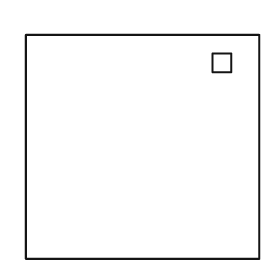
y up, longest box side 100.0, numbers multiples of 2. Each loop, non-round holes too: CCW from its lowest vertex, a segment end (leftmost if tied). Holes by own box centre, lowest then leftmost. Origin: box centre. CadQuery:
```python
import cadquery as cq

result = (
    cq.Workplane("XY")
    .moveTo(-50.0, -48.0)
    .lineTo(50.0, -48.0)
    .lineTo(50.0, 48.0)
    .lineTo(-50.0, 48.0)
    .close()
    .moveTo(30.0, 32.0)
    .lineTo(38.0, 32.0)
    .lineTo(38.0, 40.0)
    .lineTo(30.0, 40.0)
    .close()
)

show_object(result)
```